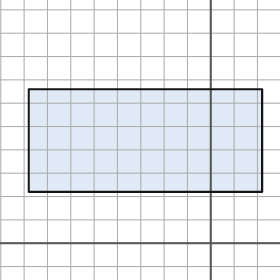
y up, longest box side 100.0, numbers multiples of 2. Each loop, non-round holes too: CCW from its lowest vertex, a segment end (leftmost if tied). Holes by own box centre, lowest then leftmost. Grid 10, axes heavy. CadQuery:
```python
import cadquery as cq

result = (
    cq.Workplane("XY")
    .moveTo(-78.0, 22.0)
    .lineTo(22.0, 22.0)
    .lineTo(22.0, 66.0)
    .lineTo(-78.0, 66.0)
    .close()
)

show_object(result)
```